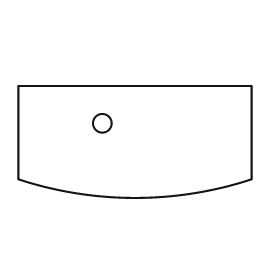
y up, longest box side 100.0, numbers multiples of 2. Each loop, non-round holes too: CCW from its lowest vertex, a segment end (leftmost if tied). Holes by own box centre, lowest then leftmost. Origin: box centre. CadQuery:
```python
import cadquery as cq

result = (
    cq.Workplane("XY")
    .moveTo(-50.0, -16.0)
    .threePointArc((0.0, -24.0), (50.0, -16.0))
    .lineTo(50.0, 24.0)
    .lineTo(-50.0, 24.0)
    .close()
    .moveTo(-14.0, 8.0)
    .circle(4.0)
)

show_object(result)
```